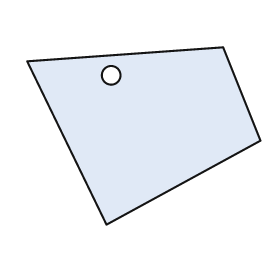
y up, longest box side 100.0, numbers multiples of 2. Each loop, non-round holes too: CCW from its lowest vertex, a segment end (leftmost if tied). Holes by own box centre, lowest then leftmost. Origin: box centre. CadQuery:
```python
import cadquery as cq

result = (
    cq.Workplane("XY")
    .moveTo(-16.0, -38.0)
    .lineTo(50.0, -2.0)
    .lineTo(34.0, 38.0)
    .lineTo(-50.0, 32.0)
    .close()
    .moveTo(-14.0, 26.0)
    .circle(4.0)
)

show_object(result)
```